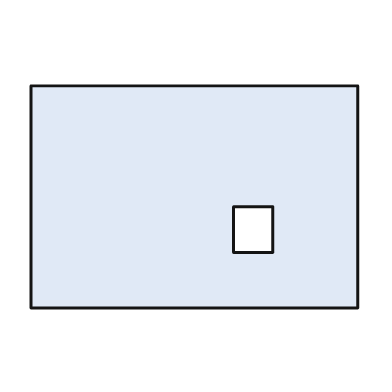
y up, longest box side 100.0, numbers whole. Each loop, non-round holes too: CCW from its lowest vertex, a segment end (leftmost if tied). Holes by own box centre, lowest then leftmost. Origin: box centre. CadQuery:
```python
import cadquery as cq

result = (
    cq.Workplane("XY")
    .moveTo(-50.0, -34.0)
    .lineTo(50.0, -34.0)
    .lineTo(50.0, 34.0)
    .lineTo(-50.0, 34.0)
    .close()
    .moveTo(12.0, -17.0)
    .lineTo(24.0, -17.0)
    .lineTo(24.0, -3.0)
    .lineTo(12.0, -3.0)
    .close()
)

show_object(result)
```